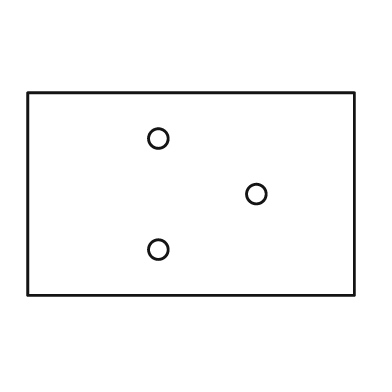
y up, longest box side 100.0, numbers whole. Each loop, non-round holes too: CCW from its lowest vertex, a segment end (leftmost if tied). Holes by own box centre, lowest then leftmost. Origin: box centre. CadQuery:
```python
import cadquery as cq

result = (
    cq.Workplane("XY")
    .moveTo(-50.0, -31.0)
    .lineTo(50.0, -31.0)
    .lineTo(50.0, 31.0)
    .lineTo(-50.0, 31.0)
    .close()
    .moveTo(-10.0, -17.0)
    .circle(3.0)
    .moveTo(20.0, 0.0)
    .circle(3.0)
    .moveTo(-10.0, 17.0)
    .circle(3.0)
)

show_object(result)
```